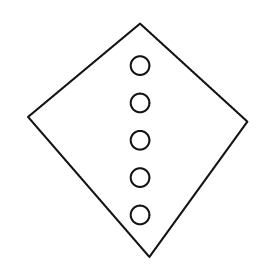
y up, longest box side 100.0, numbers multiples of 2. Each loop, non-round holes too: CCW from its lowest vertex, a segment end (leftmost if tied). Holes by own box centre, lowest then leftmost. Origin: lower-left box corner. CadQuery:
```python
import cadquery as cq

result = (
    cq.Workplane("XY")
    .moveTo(52.0, 0.0)
    .lineTo(94.0, 58.0)
    .lineTo(48.0, 100.0)
    .lineTo(0.0, 60.0)
    .close()
    .moveTo(48.0, 18.0)
    .circle(4.0)
    .moveTo(48.0, 34.0)
    .circle(4.0)
    .moveTo(48.0, 50.0)
    .circle(4.0)
    .moveTo(48.0, 66.0)
    .circle(4.0)
    .moveTo(48.0, 82.0)
    .circle(4.0)
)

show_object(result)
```